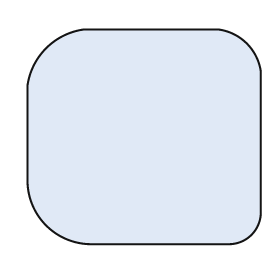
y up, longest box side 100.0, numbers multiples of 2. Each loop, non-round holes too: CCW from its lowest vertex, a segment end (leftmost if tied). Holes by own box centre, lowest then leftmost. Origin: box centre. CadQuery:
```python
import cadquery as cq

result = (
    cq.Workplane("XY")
    .moveTo(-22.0, -46.0)
    .lineTo(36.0, -46.0)
    .threePointArc((46.0, -42.0), (50.0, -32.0))
    .lineTo(50.0, 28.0)
    .threePointArc((44.0, 40.0), (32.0, 46.0))
    .lineTo(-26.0, 46.0)
    .threePointArc((-42.0, 38.0), (-50.0, 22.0))
    .lineTo(-50.0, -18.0)
    .threePointArc((-42.0, -38.0), (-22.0, -46.0))
    .close()
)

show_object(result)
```